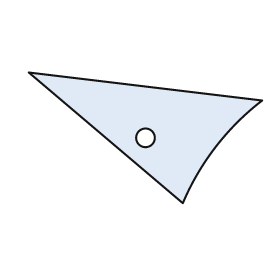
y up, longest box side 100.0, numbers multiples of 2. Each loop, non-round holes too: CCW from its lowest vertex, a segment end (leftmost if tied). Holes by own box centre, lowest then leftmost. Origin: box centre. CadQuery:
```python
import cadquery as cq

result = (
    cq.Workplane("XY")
    .moveTo(16.0, -28.0)
    .threePointArc((30.0, -4.0), (50.0, 16.0))
    .lineTo(-50.0, 28.0)
    .close()
    .moveTo(0.0, 0.0)
    .circle(4.0)
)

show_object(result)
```